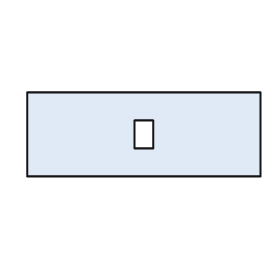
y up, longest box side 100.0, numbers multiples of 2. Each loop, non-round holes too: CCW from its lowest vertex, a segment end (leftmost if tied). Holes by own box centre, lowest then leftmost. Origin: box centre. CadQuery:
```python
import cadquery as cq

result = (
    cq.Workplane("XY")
    .moveTo(-50.0, -18.0)
    .lineTo(50.0, -18.0)
    .lineTo(50.0, 18.0)
    .lineTo(-50.0, 18.0)
    .close()
    .moveTo(-4.0, -6.0)
    .lineTo(4.0, -6.0)
    .lineTo(4.0, 6.0)
    .lineTo(-4.0, 6.0)
    .close()
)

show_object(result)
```